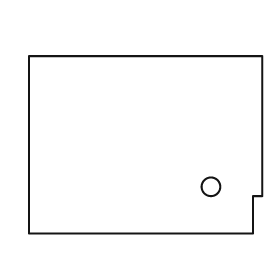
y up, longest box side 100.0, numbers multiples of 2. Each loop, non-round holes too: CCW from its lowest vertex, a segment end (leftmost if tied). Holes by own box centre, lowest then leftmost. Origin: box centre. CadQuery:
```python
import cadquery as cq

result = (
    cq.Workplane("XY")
    .moveTo(-50.0, -38.0)
    .lineTo(46.0, -38.0)
    .lineTo(46.0, -22.0)
    .lineTo(50.0, -22.0)
    .lineTo(50.0, 38.0)
    .lineTo(-50.0, 38.0)
    .close()
    .moveTo(28.0, -18.0)
    .circle(4.0)
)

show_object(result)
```